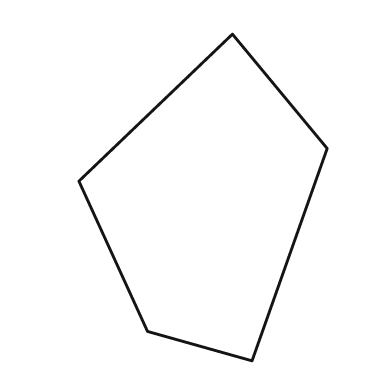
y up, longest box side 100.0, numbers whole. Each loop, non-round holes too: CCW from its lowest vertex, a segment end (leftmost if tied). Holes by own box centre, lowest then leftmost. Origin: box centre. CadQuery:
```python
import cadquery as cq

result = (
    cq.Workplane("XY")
    .moveTo(15.0, -50.0)
    .lineTo(38.0, 15.0)
    .lineTo(9.0, 50.0)
    .lineTo(-38.0, 5.0)
    .lineTo(-17.0, -41.0)
    .close()
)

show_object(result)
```